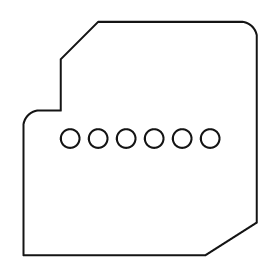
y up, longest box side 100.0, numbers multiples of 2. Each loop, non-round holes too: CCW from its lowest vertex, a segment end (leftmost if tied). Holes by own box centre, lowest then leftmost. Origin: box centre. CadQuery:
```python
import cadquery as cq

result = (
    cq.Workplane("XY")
    .moveTo(-50.0, -50.0)
    .lineTo(28.0, -50.0)
    .lineTo(50.0, -36.0)
    .lineTo(50.0, 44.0)
    .threePointArc((48.0, 48.0), (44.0, 50.0))
    .lineTo(-18.0, 50.0)
    .lineTo(-34.0, 34.0)
    .lineTo(-34.0, 12.0)
    .lineTo(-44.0, 12.0)
    .threePointArc((-48.0, 10.0), (-50.0, 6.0))
    .close()
    .moveTo(-30.0, 0.0)
    .circle(4.0)
    .moveTo(-18.0, 0.0)
    .circle(4.0)
    .moveTo(-6.0, 0.0)
    .circle(4.0)
    .moveTo(6.0, 0.0)
    .circle(4.0)
    .moveTo(18.0, 0.0)
    .circle(4.0)
    .moveTo(30.0, 0.0)
    .circle(4.0)
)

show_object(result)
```